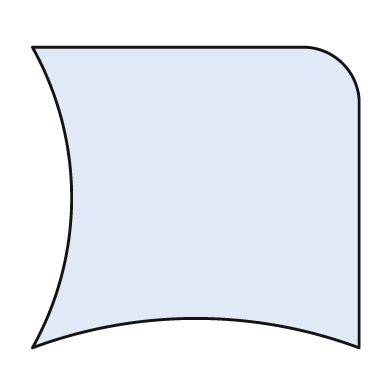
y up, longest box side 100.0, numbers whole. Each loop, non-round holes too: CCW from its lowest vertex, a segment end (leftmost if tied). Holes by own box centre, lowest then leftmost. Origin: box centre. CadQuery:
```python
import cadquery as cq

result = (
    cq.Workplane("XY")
    .moveTo(-50.0, -46.0)
    .threePointArc((0.0, -37.0), (50.0, -46.0))
    .lineTo(50.0, 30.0)
    .threePointArc((45.0, 41.0), (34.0, 46.0))
    .lineTo(-50.0, 46.0)
    .threePointArc((-38.0, 0.0), (-50.0, -46.0))
    .close()
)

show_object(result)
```